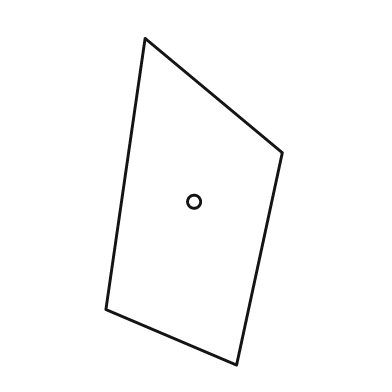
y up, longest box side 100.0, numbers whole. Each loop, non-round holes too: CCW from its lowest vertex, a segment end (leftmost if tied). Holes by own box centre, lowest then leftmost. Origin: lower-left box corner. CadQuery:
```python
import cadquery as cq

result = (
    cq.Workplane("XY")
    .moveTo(40.0, 0.0)
    .lineTo(54.0, 65.0)
    .lineTo(12.0, 100.0)
    .lineTo(0.0, 17.0)
    .close()
    .moveTo(27.0, 50.0)
    .circle(2.0)
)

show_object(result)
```